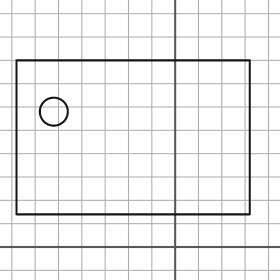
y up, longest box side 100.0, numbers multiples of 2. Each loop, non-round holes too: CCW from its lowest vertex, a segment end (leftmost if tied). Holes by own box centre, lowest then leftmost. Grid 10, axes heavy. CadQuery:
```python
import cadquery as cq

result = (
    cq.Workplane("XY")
    .moveTo(-68.0, 14.0)
    .lineTo(32.0, 14.0)
    .lineTo(32.0, 80.0)
    .lineTo(-68.0, 80.0)
    .close()
    .moveTo(-52.0, 58.0)
    .circle(6.0)
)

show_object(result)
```